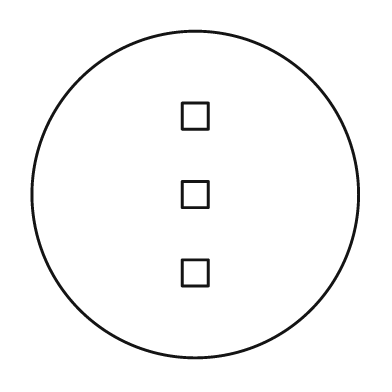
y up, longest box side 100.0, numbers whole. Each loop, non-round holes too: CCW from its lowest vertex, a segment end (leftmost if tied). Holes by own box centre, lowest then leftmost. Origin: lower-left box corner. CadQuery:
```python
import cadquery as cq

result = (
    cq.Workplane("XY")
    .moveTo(50.0, 50.0)
    .circle(50.0)
    .moveTo(46.0, 22.0)
    .lineTo(54.0, 22.0)
    .lineTo(54.0, 30.0)
    .lineTo(46.0, 30.0)
    .close()
    .moveTo(46.0, 46.0)
    .lineTo(54.0, 46.0)
    .lineTo(54.0, 54.0)
    .lineTo(46.0, 54.0)
    .close()
    .moveTo(46.0, 70.0)
    .lineTo(54.0, 70.0)
    .lineTo(54.0, 78.0)
    .lineTo(46.0, 78.0)
    .close()
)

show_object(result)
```